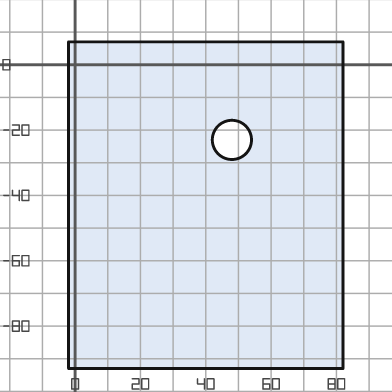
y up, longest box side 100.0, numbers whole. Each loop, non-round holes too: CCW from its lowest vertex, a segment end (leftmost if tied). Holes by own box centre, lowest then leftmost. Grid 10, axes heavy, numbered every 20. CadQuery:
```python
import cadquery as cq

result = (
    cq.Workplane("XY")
    .moveTo(-2.0, -93.0)
    .lineTo(82.0, -93.0)
    .lineTo(82.0, 7.0)
    .lineTo(-2.0, 7.0)
    .close()
    .moveTo(48.0, -23.0)
    .circle(6.0)
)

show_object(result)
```